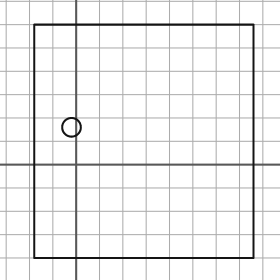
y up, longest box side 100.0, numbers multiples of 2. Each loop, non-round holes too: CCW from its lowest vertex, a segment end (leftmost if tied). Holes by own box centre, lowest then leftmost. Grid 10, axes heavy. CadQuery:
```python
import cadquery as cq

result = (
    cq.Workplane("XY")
    .moveTo(-18.0, -40.0)
    .lineTo(76.0, -40.0)
    .lineTo(76.0, 60.0)
    .lineTo(-18.0, 60.0)
    .close()
    .moveTo(-2.0, 16.0)
    .circle(4.0)
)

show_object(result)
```